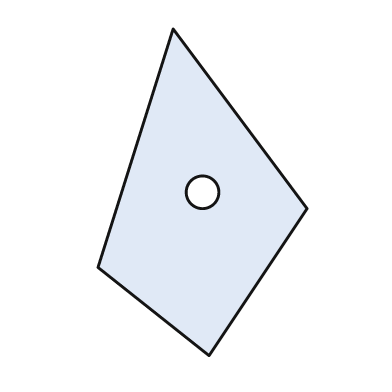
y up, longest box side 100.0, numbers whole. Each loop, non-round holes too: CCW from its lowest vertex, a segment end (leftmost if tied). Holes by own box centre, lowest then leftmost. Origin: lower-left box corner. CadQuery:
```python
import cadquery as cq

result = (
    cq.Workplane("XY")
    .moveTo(34.0, 0.0)
    .lineTo(64.0, 45.0)
    .lineTo(23.0, 100.0)
    .lineTo(0.0, 27.0)
    .close()
    .moveTo(32.0, 50.0)
    .circle(5.0)
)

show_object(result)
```